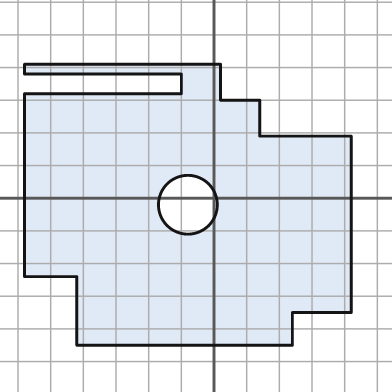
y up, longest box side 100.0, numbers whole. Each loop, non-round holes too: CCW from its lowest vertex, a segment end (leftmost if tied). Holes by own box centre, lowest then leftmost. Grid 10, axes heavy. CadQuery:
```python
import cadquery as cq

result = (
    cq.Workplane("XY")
    .moveTo(-42.0, -45.0)
    .lineTo(24.0, -45.0)
    .lineTo(24.0, -35.0)
    .lineTo(42.0, -35.0)
    .lineTo(42.0, 19.0)
    .lineTo(14.0, 19.0)
    .lineTo(14.0, 30.0)
    .lineTo(2.0, 30.0)
    .lineTo(2.0, 41.0)
    .lineTo(-58.0, 41.0)
    .lineTo(-58.0, 38.0)
    .lineTo(-10.0, 38.0)
    .lineTo(-10.0, 32.0)
    .lineTo(-58.0, 32.0)
    .lineTo(-58.0, -24.0)
    .lineTo(-42.0, -24.0)
    .close()
    .moveTo(-8.0, -2.0)
    .circle(9.0)
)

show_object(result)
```